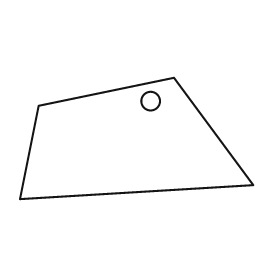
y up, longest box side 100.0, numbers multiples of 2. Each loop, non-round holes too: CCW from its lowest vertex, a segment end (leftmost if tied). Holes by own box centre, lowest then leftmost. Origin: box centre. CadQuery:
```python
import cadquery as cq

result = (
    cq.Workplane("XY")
    .moveTo(-50.0, -26.0)
    .lineTo(50.0, -20.0)
    .lineTo(16.0, 26.0)
    .lineTo(-42.0, 14.0)
    .close()
    .moveTo(6.0, 16.0)
    .circle(4.0)
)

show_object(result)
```